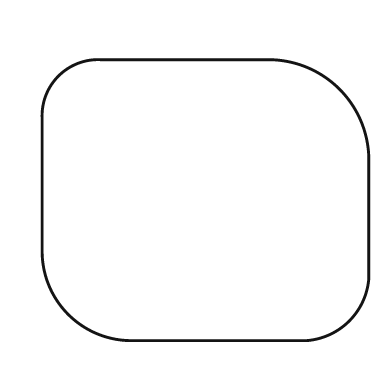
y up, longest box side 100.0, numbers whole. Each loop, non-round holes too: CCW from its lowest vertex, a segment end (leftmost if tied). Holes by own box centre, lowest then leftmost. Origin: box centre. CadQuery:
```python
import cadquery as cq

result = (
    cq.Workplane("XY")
    .moveTo(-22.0, -43.0)
    .lineTo(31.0, -43.0)
    .threePointArc((44.0, -37.0), (50.0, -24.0))
    .lineTo(50.0, 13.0)
    .threePointArc((41.0, 34.0), (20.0, 43.0))
    .lineTo(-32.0, 43.0)
    .threePointArc((-45.0, 38.0), (-50.0, 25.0))
    .lineTo(-50.0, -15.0)
    .threePointArc((-42.0, -35.0), (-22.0, -43.0))
    .close()
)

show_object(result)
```